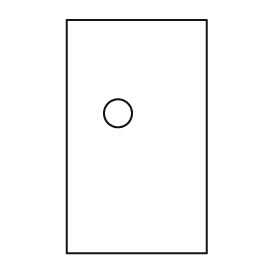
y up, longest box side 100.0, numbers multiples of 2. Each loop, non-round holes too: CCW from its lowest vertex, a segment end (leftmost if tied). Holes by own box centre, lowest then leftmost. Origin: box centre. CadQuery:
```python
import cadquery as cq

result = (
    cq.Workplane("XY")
    .moveTo(-30.0, -50.0)
    .lineTo(30.0, -50.0)
    .lineTo(30.0, 50.0)
    .lineTo(-30.0, 50.0)
    .close()
    .moveTo(-8.0, 10.0)
    .circle(6.0)
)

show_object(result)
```